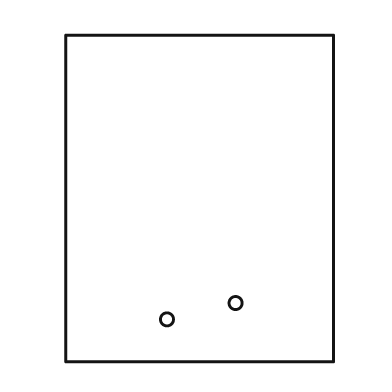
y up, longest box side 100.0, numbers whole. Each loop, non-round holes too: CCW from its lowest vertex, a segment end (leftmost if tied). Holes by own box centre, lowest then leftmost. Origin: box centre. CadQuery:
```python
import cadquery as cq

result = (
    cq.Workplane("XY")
    .moveTo(-41.0, -50.0)
    .lineTo(41.0, -50.0)
    .lineTo(41.0, 50.0)
    .lineTo(-41.0, 50.0)
    .close()
    .moveTo(-10.0, -37.0)
    .circle(2.0)
    .moveTo(11.0, -32.0)
    .circle(2.0)
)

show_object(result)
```